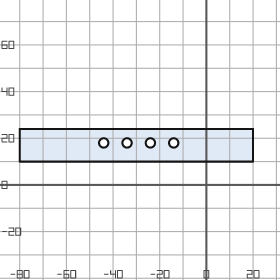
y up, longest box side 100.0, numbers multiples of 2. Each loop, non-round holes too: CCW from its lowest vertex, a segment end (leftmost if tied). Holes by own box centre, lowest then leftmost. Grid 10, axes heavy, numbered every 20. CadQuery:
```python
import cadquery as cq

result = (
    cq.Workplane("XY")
    .moveTo(-80.0, 10.0)
    .lineTo(20.0, 10.0)
    .lineTo(20.0, 24.0)
    .lineTo(-80.0, 24.0)
    .close()
    .moveTo(-44.0, 18.0)
    .circle(2.0)
    .moveTo(-34.0, 18.0)
    .circle(2.0)
    .moveTo(-24.0, 18.0)
    .circle(2.0)
    .moveTo(-14.0, 18.0)
    .circle(2.0)
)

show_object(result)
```